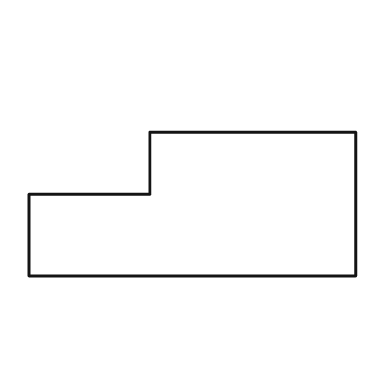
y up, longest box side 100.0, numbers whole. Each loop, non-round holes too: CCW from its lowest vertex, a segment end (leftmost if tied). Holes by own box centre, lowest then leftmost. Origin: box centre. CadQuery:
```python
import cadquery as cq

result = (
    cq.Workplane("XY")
    .moveTo(-50.0, -22.0)
    .lineTo(50.0, -22.0)
    .lineTo(50.0, 22.0)
    .lineTo(-13.0, 22.0)
    .lineTo(-13.0, 3.0)
    .lineTo(-50.0, 3.0)
    .close()
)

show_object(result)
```